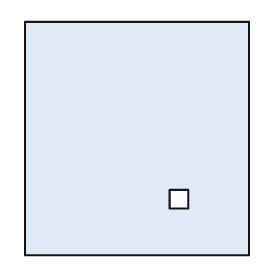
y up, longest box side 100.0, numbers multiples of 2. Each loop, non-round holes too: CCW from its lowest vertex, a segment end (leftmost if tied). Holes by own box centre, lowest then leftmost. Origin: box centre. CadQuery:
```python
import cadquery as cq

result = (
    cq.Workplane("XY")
    .moveTo(-48.0, -50.0)
    .lineTo(48.0, -50.0)
    .lineTo(48.0, 50.0)
    .lineTo(-48.0, 50.0)
    .close()
    .moveTo(14.0, -30.0)
    .lineTo(22.0, -30.0)
    .lineTo(22.0, -22.0)
    .lineTo(14.0, -22.0)
    .close()
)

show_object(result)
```